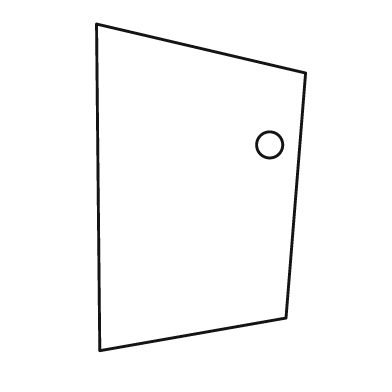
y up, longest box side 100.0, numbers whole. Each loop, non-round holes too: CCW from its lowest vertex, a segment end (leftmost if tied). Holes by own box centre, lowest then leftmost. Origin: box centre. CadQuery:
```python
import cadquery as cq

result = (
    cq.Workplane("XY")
    .moveTo(-31.0, -50.0)
    .lineTo(26.0, -40.0)
    .lineTo(32.0, 35.0)
    .lineTo(-32.0, 50.0)
    .close()
    .moveTo(21.0, 13.0)
    .circle(4.0)
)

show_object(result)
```